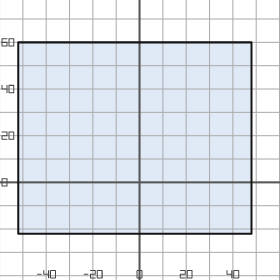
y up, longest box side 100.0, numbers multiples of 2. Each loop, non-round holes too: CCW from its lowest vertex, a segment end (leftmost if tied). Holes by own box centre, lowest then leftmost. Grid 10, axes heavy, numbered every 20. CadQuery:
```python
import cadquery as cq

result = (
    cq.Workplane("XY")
    .moveTo(-52.0, -22.0)
    .lineTo(48.0, -22.0)
    .lineTo(48.0, 60.0)
    .lineTo(-52.0, 60.0)
    .close()
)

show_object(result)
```